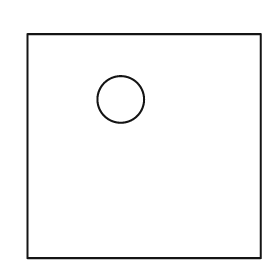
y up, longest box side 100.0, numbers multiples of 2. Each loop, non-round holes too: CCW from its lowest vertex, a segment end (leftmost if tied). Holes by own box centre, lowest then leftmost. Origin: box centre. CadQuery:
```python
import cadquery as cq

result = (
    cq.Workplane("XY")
    .moveTo(-50.0, -48.0)
    .lineTo(50.0, -48.0)
    .lineTo(50.0, 48.0)
    .lineTo(-50.0, 48.0)
    .close()
    .moveTo(-10.0, 20.0)
    .circle(10.0)
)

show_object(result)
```